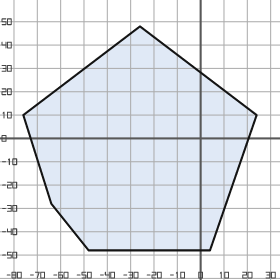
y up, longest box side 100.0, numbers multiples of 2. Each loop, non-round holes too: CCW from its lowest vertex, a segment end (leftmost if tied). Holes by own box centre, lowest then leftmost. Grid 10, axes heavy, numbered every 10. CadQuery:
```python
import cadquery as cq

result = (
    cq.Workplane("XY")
    .moveTo(-48.0, -48.0)
    .lineTo(4.0, -48.0)
    .lineTo(24.0, 10.0)
    .lineTo(-26.0, 48.0)
    .lineTo(-76.0, 10.0)
    .lineTo(-64.0, -28.0)
    .close()
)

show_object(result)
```